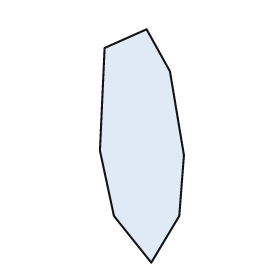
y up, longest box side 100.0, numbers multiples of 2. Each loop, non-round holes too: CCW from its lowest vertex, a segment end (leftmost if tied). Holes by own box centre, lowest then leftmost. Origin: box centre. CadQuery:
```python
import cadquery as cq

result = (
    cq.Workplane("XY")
    .moveTo(4.0, -50.0)
    .lineTo(16.0, -30.0)
    .lineTo(18.0, -4.0)
    .lineTo(12.0, 32.0)
    .lineTo(2.0, 50.0)
    .lineTo(-16.0, 42.0)
    .lineTo(-18.0, -2.0)
    .lineTo(-12.0, -30.0)
    .close()
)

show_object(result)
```